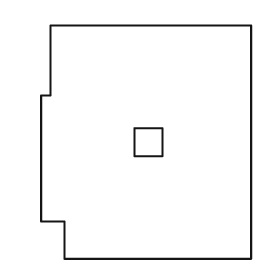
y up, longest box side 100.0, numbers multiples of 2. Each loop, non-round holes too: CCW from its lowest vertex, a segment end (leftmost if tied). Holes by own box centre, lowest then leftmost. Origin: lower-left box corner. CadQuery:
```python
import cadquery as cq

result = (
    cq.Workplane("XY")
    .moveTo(10.0, 0.0)
    .lineTo(90.0, 0.0)
    .lineTo(90.0, 100.0)
    .lineTo(4.0, 100.0)
    .lineTo(4.0, 70.0)
    .lineTo(0.0, 70.0)
    .lineTo(0.0, 16.0)
    .lineTo(10.0, 16.0)
    .close()
    .moveTo(40.0, 44.0)
    .lineTo(52.0, 44.0)
    .lineTo(52.0, 56.0)
    .lineTo(40.0, 56.0)
    .close()
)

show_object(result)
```